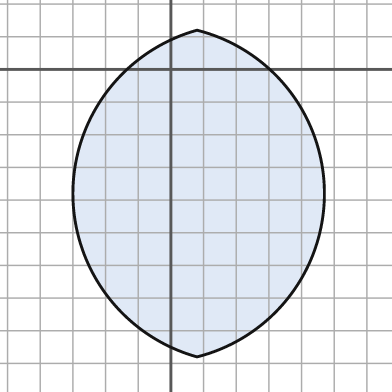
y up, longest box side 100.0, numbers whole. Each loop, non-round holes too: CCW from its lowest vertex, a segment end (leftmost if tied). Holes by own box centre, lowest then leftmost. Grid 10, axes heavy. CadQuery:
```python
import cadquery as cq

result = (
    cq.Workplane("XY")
    .moveTo(8.0, -88.0)
    .threePointArc((47.0, -38.0), (8.0, 12.0))
    .threePointArc((-30.0, -38.0), (8.0, -88.0))
    .close()
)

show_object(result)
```